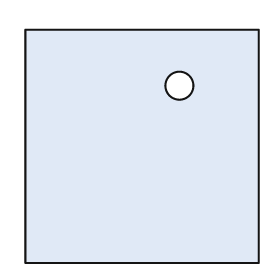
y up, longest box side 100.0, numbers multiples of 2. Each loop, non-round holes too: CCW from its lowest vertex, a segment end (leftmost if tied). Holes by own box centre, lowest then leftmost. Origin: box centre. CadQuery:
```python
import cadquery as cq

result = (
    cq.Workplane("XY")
    .moveTo(-50.0, -50.0)
    .lineTo(50.0, -50.0)
    .lineTo(50.0, 50.0)
    .lineTo(-50.0, 50.0)
    .close()
    .moveTo(16.0, 26.0)
    .circle(6.0)
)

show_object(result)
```